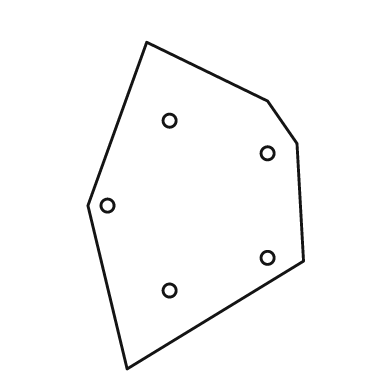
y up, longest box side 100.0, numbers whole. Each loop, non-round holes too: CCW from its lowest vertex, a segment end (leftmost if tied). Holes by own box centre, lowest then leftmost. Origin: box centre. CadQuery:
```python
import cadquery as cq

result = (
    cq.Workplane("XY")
    .moveTo(-21.0, -50.0)
    .lineTo(33.0, -17.0)
    .lineTo(31.0, 19.0)
    .lineTo(22.0, 32.0)
    .lineTo(-15.0, 50.0)
    .lineTo(-33.0, 0.0)
    .close()
    .moveTo(-8.0, -26.0)
    .circle(2.0)
    .moveTo(22.0, -16.0)
    .circle(2.0)
    .moveTo(-27.0, 0.0)
    .circle(2.0)
    .moveTo(22.0, 16.0)
    .circle(2.0)
    .moveTo(-8.0, 26.0)
    .circle(2.0)
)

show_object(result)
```